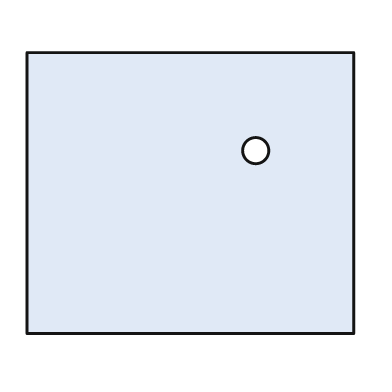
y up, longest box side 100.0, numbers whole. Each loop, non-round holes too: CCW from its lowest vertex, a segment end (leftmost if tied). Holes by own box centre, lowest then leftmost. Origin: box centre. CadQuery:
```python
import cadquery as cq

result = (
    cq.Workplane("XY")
    .moveTo(-50.0, -43.0)
    .lineTo(50.0, -43.0)
    .lineTo(50.0, 43.0)
    .lineTo(-50.0, 43.0)
    .close()
    .moveTo(20.0, 13.0)
    .circle(4.0)
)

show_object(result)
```